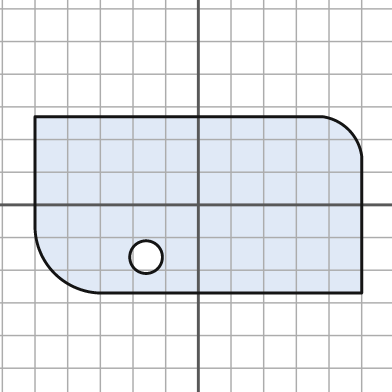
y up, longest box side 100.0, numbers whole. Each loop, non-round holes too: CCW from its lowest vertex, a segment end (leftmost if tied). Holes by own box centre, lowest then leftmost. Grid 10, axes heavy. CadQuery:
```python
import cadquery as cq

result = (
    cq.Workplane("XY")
    .moveTo(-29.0, -27.0)
    .lineTo(50.0, -27.0)
    .lineTo(50.0, 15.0)
    .threePointArc((46.0, 23.0), (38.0, 27.0))
    .lineTo(-50.0, 27.0)
    .lineTo(-50.0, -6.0)
    .threePointArc((-44.0, -21.0), (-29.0, -27.0))
    .close()
    .moveTo(-16.0, -16.0)
    .circle(5.0)
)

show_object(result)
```